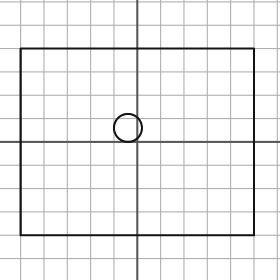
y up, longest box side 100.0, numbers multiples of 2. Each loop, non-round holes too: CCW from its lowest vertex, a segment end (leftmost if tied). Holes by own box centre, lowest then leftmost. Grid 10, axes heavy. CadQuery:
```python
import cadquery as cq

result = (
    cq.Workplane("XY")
    .moveTo(-50.0, -40.0)
    .lineTo(50.0, -40.0)
    .lineTo(50.0, 40.0)
    .lineTo(-50.0, 40.0)
    .close()
    .moveTo(-4.0, 6.0)
    .circle(6.0)
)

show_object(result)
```